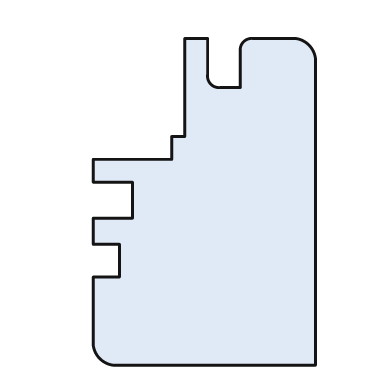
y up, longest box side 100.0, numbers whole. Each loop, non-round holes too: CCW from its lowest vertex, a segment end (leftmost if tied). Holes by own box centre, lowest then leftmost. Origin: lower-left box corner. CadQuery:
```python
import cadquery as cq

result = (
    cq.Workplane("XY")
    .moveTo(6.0, 0.0)
    .lineTo(68.0, 0.0)
    .lineTo(68.0, 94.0)
    .threePointArc((66.0, 98.0), (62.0, 100.0))
    .lineTo(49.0, 100.0)
    .threePointArc((46.0, 99.0), (45.0, 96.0))
    .lineTo(45.0, 85.0)
    .lineTo(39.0, 85.0)
    .threePointArc((36.0, 86.0), (35.0, 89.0))
    .lineTo(35.0, 100.0)
    .lineTo(28.0, 100.0)
    .lineTo(28.0, 70.0)
    .lineTo(24.0, 70.0)
    .lineTo(24.0, 63.0)
    .lineTo(0.0, 63.0)
    .lineTo(0.0, 56.0)
    .lineTo(12.0, 56.0)
    .lineTo(12.0, 45.0)
    .lineTo(0.0, 45.0)
    .lineTo(0.0, 37.0)
    .lineTo(8.0, 37.0)
    .lineTo(8.0, 27.0)
    .lineTo(0.0, 27.0)
    .lineTo(0.0, 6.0)
    .threePointArc((2.0, 2.0), (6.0, 0.0))
    .close()
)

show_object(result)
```